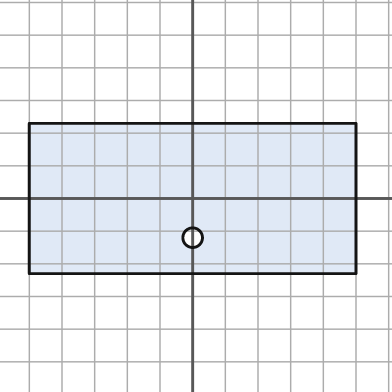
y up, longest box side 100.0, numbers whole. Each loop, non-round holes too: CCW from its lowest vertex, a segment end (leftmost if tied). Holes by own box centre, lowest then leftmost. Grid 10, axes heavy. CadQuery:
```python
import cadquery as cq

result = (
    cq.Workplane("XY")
    .moveTo(-50.0, -23.0)
    .lineTo(50.0, -23.0)
    .lineTo(50.0, 23.0)
    .lineTo(-50.0, 23.0)
    .close()
    .moveTo(0.0, -12.0)
    .circle(3.0)
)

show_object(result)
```